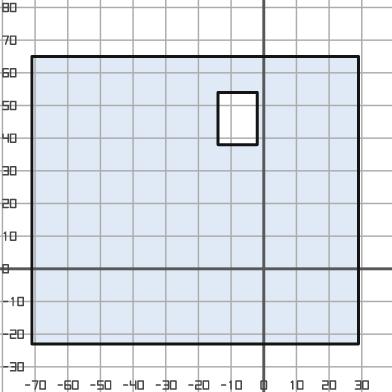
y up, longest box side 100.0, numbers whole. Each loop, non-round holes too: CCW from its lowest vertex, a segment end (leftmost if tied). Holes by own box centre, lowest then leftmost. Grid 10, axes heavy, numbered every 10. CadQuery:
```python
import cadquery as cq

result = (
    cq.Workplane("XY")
    .moveTo(-71.0, -23.0)
    .lineTo(29.0, -23.0)
    .lineTo(29.0, 65.0)
    .lineTo(-71.0, 65.0)
    .close()
    .moveTo(-14.0, 38.0)
    .lineTo(-2.0, 38.0)
    .lineTo(-2.0, 54.0)
    .lineTo(-14.0, 54.0)
    .close()
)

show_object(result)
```